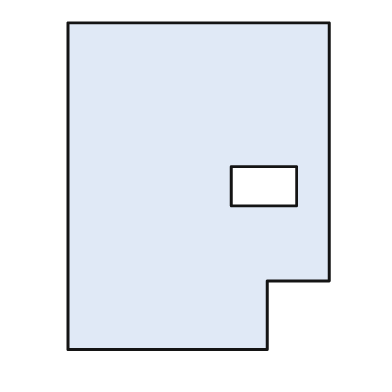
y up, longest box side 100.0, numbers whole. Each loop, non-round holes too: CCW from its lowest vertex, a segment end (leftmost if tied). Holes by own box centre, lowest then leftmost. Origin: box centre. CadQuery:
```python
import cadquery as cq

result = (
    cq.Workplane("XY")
    .moveTo(-40.0, -50.0)
    .lineTo(21.0, -50.0)
    .lineTo(21.0, -29.0)
    .lineTo(40.0, -29.0)
    .lineTo(40.0, 50.0)
    .lineTo(-40.0, 50.0)
    .close()
    .moveTo(10.0, -6.0)
    .lineTo(30.0, -6.0)
    .lineTo(30.0, 6.0)
    .lineTo(10.0, 6.0)
    .close()
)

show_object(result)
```